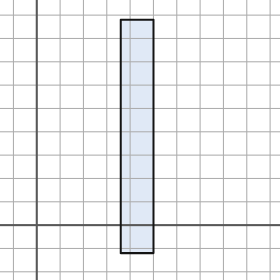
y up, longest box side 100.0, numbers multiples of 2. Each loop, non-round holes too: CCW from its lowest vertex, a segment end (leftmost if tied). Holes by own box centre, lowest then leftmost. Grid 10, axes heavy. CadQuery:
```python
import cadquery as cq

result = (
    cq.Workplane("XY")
    .moveTo(36.0, -12.0)
    .lineTo(50.0, -12.0)
    .lineTo(50.0, 88.0)
    .lineTo(36.0, 88.0)
    .close()
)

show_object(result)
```